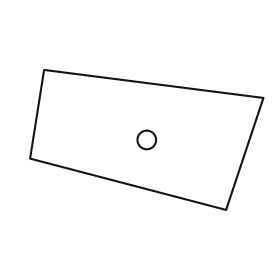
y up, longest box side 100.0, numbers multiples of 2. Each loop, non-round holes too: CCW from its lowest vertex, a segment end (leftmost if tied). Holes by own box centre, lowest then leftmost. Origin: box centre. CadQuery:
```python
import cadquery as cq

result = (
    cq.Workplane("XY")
    .moveTo(34.0, -30.0)
    .lineTo(50.0, 18.0)
    .lineTo(-44.0, 30.0)
    .lineTo(-50.0, -8.0)
    .close()
    .moveTo(0.0, 0.0)
    .circle(4.0)
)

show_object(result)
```